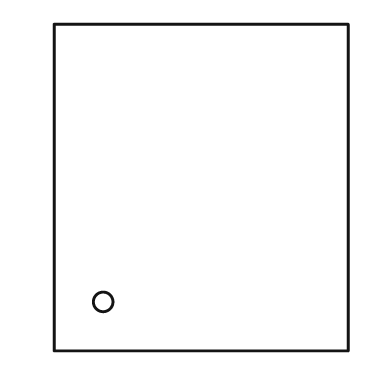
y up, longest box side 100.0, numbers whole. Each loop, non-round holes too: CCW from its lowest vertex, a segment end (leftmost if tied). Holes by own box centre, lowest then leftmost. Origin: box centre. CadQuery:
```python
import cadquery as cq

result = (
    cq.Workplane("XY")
    .moveTo(-45.0, -50.0)
    .lineTo(45.0, -50.0)
    .lineTo(45.0, 50.0)
    .lineTo(-45.0, 50.0)
    .close()
    .moveTo(-30.0, -35.0)
    .circle(3.0)
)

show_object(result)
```